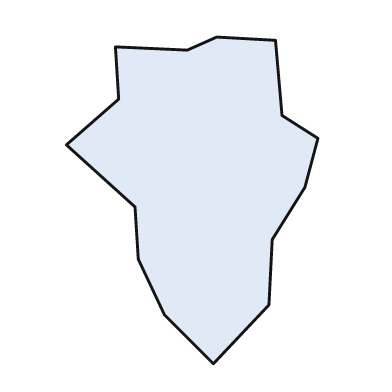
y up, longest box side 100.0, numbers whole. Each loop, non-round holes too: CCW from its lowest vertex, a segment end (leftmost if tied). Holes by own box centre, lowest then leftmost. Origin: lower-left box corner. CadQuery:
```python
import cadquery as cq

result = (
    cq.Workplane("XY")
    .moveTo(45.0, 0.0)
    .lineTo(62.0, 18.0)
    .lineTo(63.0, 38.0)
    .lineTo(73.0, 54.0)
    .lineTo(77.0, 69.0)
    .lineTo(66.0, 76.0)
    .lineTo(64.0, 99.0)
    .lineTo(46.0, 100.0)
    .lineTo(37.0, 96.0)
    .lineTo(15.0, 97.0)
    .lineTo(16.0, 81.0)
    .lineTo(0.0, 67.0)
    .lineTo(21.0, 48.0)
    .lineTo(22.0, 32.0)
    .lineTo(30.0, 15.0)
    .close()
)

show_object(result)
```